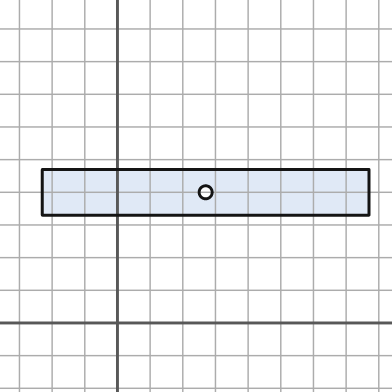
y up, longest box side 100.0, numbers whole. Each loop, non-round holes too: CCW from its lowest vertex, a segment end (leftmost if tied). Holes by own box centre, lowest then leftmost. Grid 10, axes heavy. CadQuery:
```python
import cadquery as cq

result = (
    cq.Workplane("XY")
    .moveTo(-23.0, 33.0)
    .lineTo(77.0, 33.0)
    .lineTo(77.0, 47.0)
    .lineTo(-23.0, 47.0)
    .close()
    .moveTo(27.0, 40.0)
    .circle(2.0)
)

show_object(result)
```